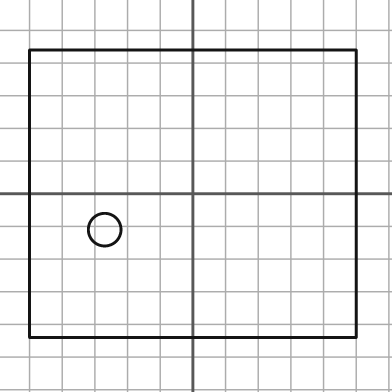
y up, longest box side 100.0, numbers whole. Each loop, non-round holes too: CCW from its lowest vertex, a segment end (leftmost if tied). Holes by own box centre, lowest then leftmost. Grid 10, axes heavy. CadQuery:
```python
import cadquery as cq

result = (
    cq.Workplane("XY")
    .moveTo(-50.0, -44.0)
    .lineTo(50.0, -44.0)
    .lineTo(50.0, 44.0)
    .lineTo(-50.0, 44.0)
    .close()
    .moveTo(-27.0, -11.0)
    .circle(5.0)
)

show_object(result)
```